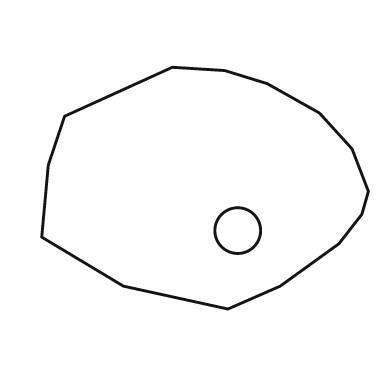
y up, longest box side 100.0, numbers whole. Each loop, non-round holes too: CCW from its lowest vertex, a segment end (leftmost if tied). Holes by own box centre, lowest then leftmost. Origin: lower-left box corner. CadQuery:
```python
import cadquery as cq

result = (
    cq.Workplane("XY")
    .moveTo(57.0, 0.0)
    .lineTo(73.0, 7.0)
    .lineTo(91.0, 20.0)
    .lineTo(98.0, 29.0)
    .lineTo(100.0, 36.0)
    .lineTo(95.0, 49.0)
    .lineTo(85.0, 60.0)
    .lineTo(69.0, 69.0)
    .lineTo(56.0, 73.0)
    .lineTo(40.0, 74.0)
    .lineTo(7.0, 59.0)
    .lineTo(2.0, 44.0)
    .lineTo(0.0, 22.0)
    .lineTo(25.0, 7.0)
    .close()
    .moveTo(60.0, 24.0)
    .circle(7.0)
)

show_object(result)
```